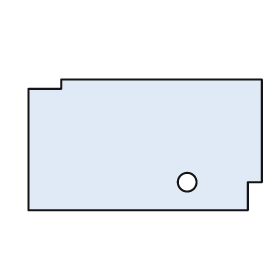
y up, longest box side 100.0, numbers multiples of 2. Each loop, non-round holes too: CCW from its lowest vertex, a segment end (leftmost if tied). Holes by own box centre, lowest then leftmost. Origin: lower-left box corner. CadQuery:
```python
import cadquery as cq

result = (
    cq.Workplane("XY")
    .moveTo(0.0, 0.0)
    .lineTo(94.0, 0.0)
    .lineTo(94.0, 12.0)
    .lineTo(100.0, 12.0)
    .lineTo(100.0, 56.0)
    .lineTo(14.0, 56.0)
    .lineTo(14.0, 52.0)
    .lineTo(0.0, 52.0)
    .close()
    .moveTo(68.0, 12.0)
    .circle(4.0)
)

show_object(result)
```